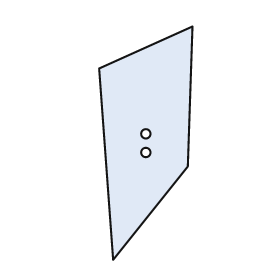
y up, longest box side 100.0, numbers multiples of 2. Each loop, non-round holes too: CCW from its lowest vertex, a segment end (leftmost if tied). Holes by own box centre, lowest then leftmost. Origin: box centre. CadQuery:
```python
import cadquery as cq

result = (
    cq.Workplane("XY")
    .moveTo(-14.0, -50.0)
    .lineTo(18.0, -10.0)
    .lineTo(20.0, 50.0)
    .lineTo(-20.0, 32.0)
    .close()
    .moveTo(0.0, -4.0)
    .circle(2.0)
    .moveTo(0.0, 4.0)
    .circle(2.0)
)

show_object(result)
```